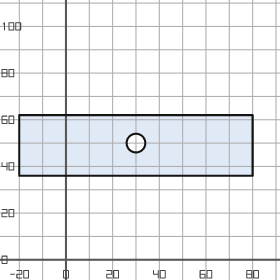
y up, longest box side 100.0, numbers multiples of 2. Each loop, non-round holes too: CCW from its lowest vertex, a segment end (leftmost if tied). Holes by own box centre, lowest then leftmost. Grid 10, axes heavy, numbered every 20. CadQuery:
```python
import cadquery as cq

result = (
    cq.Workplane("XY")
    .moveTo(-20.0, 36.0)
    .lineTo(80.0, 36.0)
    .lineTo(80.0, 62.0)
    .lineTo(-20.0, 62.0)
    .close()
    .moveTo(30.0, 50.0)
    .circle(4.0)
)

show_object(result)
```